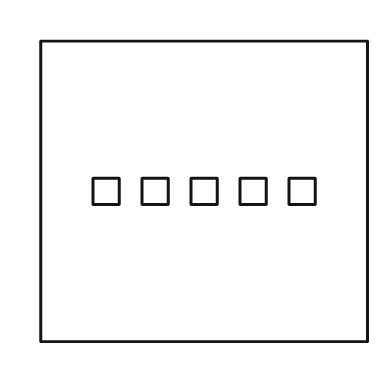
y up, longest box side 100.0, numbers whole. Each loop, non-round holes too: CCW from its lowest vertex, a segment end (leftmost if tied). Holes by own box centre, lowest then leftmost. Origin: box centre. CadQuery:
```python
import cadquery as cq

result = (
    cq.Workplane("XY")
    .moveTo(-50.0, -46.0)
    .lineTo(50.0, -46.0)
    .lineTo(50.0, 46.0)
    .lineTo(-50.0, 46.0)
    .close()
    .moveTo(-34.0, -4.0)
    .lineTo(-26.0, -4.0)
    .lineTo(-26.0, 4.0)
    .lineTo(-34.0, 4.0)
    .close()
    .moveTo(-19.0, -4.0)
    .lineTo(-11.0, -4.0)
    .lineTo(-11.0, 4.0)
    .lineTo(-19.0, 4.0)
    .close()
    .moveTo(-4.0, -4.0)
    .lineTo(4.0, -4.0)
    .lineTo(4.0, 4.0)
    .lineTo(-4.0, 4.0)
    .close()
    .moveTo(11.0, -4.0)
    .lineTo(19.0, -4.0)
    .lineTo(19.0, 4.0)
    .lineTo(11.0, 4.0)
    .close()
    .moveTo(26.0, -4.0)
    .lineTo(34.0, -4.0)
    .lineTo(34.0, 4.0)
    .lineTo(26.0, 4.0)
    .close()
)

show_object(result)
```